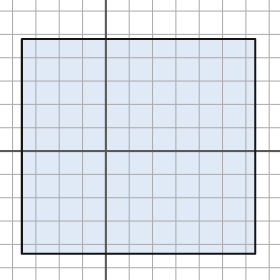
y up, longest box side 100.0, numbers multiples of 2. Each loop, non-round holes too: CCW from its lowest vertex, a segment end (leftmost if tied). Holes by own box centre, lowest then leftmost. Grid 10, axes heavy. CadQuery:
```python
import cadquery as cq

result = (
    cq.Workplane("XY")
    .moveTo(-36.0, -44.0)
    .lineTo(64.0, -44.0)
    .lineTo(64.0, 48.0)
    .lineTo(-36.0, 48.0)
    .close()
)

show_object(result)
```